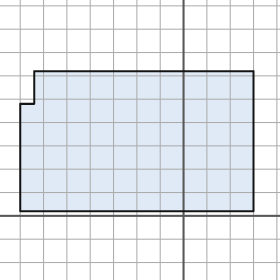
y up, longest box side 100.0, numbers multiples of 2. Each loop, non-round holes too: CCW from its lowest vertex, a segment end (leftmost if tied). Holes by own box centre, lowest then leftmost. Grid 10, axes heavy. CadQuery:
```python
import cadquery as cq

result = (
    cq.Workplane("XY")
    .moveTo(-70.0, 2.0)
    .lineTo(30.0, 2.0)
    .lineTo(30.0, 62.0)
    .lineTo(-64.0, 62.0)
    .lineTo(-64.0, 48.0)
    .lineTo(-70.0, 48.0)
    .close()
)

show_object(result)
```